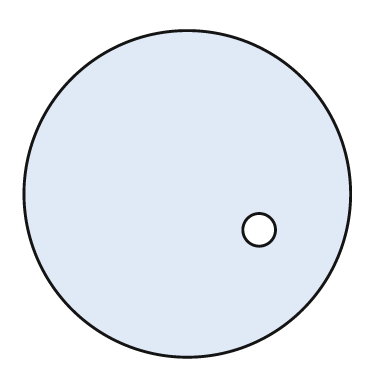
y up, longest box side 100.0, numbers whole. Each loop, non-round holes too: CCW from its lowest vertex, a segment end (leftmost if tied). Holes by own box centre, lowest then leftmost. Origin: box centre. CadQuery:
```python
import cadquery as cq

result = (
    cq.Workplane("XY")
    .moveTo(0.0, 0.0)
    .circle(50.0)
    .moveTo(22.0, -11.0)
    .circle(5.0)
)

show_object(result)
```